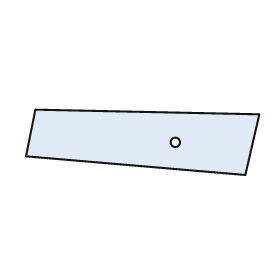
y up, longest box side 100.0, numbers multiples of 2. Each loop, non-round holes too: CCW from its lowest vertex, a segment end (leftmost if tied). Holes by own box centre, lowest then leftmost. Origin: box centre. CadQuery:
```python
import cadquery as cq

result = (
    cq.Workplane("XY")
    .moveTo(44.0, -14.0)
    .lineTo(50.0, 12.0)
    .lineTo(-46.0, 14.0)
    .lineTo(-50.0, -6.0)
    .close()
    .moveTo(14.0, 0.0)
    .circle(2.0)
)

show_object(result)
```